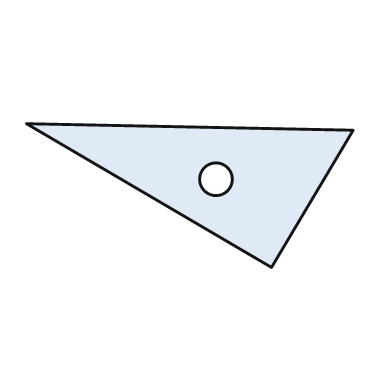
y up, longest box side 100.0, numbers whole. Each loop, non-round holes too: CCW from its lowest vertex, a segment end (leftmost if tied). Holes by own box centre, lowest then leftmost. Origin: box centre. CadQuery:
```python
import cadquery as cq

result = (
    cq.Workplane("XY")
    .moveTo(25.0, -22.0)
    .lineTo(50.0, 20.0)
    .lineTo(-50.0, 22.0)
    .close()
    .moveTo(8.0, 5.0)
    .circle(5.0)
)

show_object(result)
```